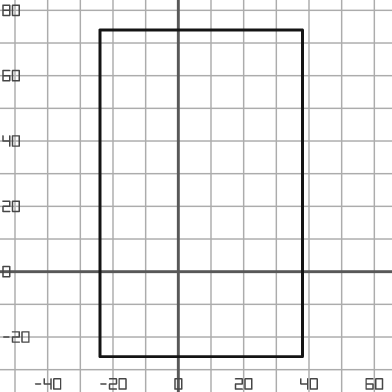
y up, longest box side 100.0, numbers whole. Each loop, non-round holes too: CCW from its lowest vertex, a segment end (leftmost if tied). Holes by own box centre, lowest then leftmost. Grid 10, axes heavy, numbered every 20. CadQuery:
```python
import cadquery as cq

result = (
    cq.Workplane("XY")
    .moveTo(-24.0, -26.0)
    .lineTo(38.0, -26.0)
    .lineTo(38.0, 74.0)
    .lineTo(-24.0, 74.0)
    .close()
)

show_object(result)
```